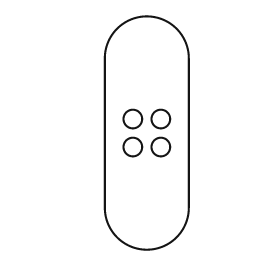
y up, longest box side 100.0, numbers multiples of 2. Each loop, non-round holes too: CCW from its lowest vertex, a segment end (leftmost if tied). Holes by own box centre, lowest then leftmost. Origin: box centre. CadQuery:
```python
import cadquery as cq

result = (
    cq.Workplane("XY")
    .moveTo(-18.0, -32.0)
    .threePointArc((0.0, -50.0), (18.0, -32.0))
    .lineTo(18.0, 32.0)
    .threePointArc((0.0, 50.0), (-18.0, 32.0))
    .close()
    .moveTo(-6.0, -6.0)
    .circle(4.0)
    .moveTo(6.0, -6.0)
    .circle(4.0)
    .moveTo(-6.0, 6.0)
    .circle(4.0)
    .moveTo(6.0, 6.0)
    .circle(4.0)
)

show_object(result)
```